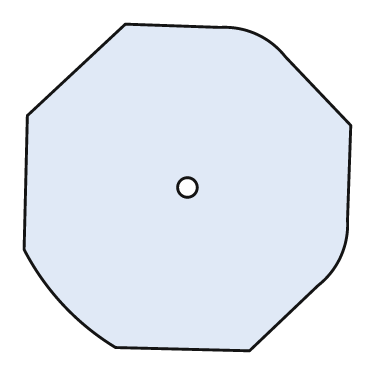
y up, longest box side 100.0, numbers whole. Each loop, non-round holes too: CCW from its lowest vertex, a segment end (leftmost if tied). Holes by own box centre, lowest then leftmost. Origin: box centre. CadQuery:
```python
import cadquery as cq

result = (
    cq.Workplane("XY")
    .moveTo(19.0, -50.0)
    .lineTo(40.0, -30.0)
    .threePointArc((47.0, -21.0), (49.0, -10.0))
    .lineTo(50.0, 19.0)
    .lineTo(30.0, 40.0)
    .threePointArc((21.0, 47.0), (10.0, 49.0))
    .lineTo(-19.0, 50.0)
    .lineTo(-49.0, 22.0)
    .lineTo(-50.0, -19.0)
    .threePointArc((-38.0, -36.0), (-22.0, -49.0))
    .close()
    .moveTo(0.0, 0.0)
    .circle(3.0)
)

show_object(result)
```